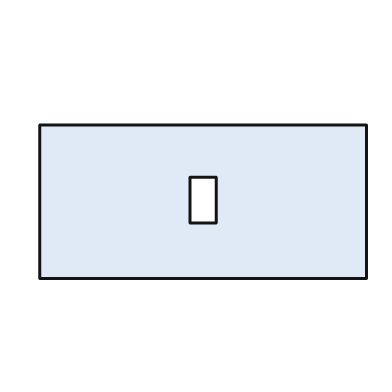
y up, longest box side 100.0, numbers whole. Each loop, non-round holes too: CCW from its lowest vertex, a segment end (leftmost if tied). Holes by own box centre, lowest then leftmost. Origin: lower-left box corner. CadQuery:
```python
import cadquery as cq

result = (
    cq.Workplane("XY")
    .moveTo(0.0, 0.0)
    .lineTo(100.0, 0.0)
    .lineTo(100.0, 47.0)
    .lineTo(0.0, 47.0)
    .close()
    .moveTo(46.0, 17.0)
    .lineTo(54.0, 17.0)
    .lineTo(54.0, 31.0)
    .lineTo(46.0, 31.0)
    .close()
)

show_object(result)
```